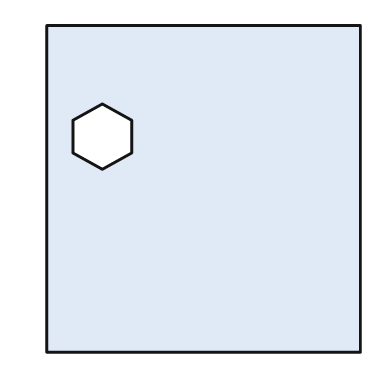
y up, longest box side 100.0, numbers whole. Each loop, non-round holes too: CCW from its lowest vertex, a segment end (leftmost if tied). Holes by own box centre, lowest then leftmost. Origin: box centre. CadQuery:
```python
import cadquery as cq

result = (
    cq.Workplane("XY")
    .moveTo(-48.0, -50.0)
    .lineTo(48.0, -50.0)
    .lineTo(48.0, 50.0)
    .lineTo(-48.0, 50.0)
    .close()
    .moveTo(-31.0, 6.0)
    .lineTo(-22.0, 11.0)
    .lineTo(-22.0, 21.0)
    .lineTo(-31.0, 26.0)
    .lineTo(-40.0, 21.0)
    .lineTo(-40.0, 11.0)
    .close()
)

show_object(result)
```